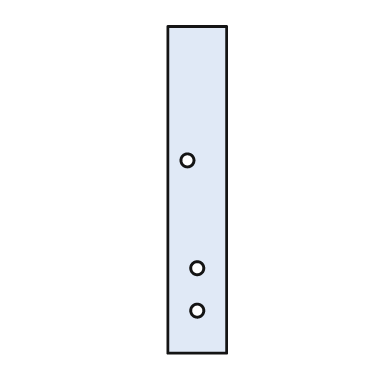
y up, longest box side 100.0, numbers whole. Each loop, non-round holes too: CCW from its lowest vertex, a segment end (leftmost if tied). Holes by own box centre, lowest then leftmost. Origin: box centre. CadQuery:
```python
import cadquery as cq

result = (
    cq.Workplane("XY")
    .moveTo(-9.0, -50.0)
    .lineTo(9.0, -50.0)
    .lineTo(9.0, 50.0)
    .lineTo(-9.0, 50.0)
    .close()
    .moveTo(0.0, -37.0)
    .circle(2.0)
    .moveTo(0.0, -24.0)
    .circle(2.0)
    .moveTo(-3.0, 9.0)
    .circle(2.0)
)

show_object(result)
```